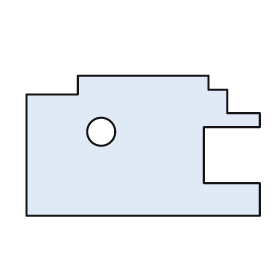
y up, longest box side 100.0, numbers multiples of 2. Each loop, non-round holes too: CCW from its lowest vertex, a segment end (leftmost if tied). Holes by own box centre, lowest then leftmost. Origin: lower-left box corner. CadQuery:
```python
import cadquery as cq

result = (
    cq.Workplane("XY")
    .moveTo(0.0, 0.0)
    .lineTo(100.0, 0.0)
    .lineTo(100.0, 14.0)
    .lineTo(76.0, 14.0)
    .lineTo(76.0, 38.0)
    .lineTo(100.0, 38.0)
    .lineTo(100.0, 44.0)
    .lineTo(86.0, 44.0)
    .lineTo(86.0, 54.0)
    .lineTo(78.0, 54.0)
    .lineTo(78.0, 60.0)
    .lineTo(22.0, 60.0)
    .lineTo(22.0, 52.0)
    .lineTo(0.0, 52.0)
    .close()
    .moveTo(32.0, 36.0)
    .circle(6.0)
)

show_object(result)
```